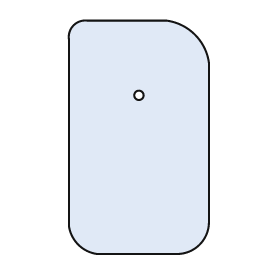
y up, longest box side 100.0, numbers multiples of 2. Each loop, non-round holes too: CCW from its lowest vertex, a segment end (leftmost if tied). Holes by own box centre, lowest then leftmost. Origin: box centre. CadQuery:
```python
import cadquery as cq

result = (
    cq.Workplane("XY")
    .moveTo(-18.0, -50.0)
    .lineTo(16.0, -50.0)
    .threePointArc((26.0, -46.0), (30.0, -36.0))
    .lineTo(30.0, 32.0)
    .threePointArc((24.0, 44.0), (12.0, 50.0))
    .lineTo(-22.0, 50.0)
    .threePointArc((-28.0, 48.0), (-30.0, 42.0))
    .lineTo(-30.0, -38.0)
    .threePointArc((-26.0, -46.0), (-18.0, -50.0))
    .close()
    .moveTo(0.0, 18.0)
    .circle(2.0)
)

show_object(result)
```